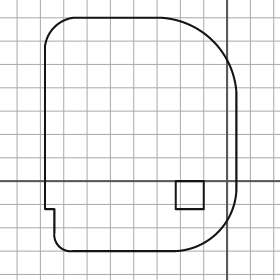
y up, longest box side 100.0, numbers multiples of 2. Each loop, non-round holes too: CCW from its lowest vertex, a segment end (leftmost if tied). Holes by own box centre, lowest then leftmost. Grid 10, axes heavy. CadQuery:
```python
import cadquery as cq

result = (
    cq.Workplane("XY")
    .moveTo(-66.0, -30.0)
    .lineTo(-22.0, -30.0)
    .threePointArc((-4.0, -22.0), (4.0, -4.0))
    .lineTo(4.0, 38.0)
    .threePointArc((-6.0, 60.0), (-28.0, 70.0))
    .lineTo(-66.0, 70.0)
    .threePointArc((-74.0, 66.0), (-78.0, 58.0))
    .lineTo(-78.0, -12.0)
    .lineTo(-74.0, -12.0)
    .lineTo(-74.0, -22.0)
    .threePointArc((-72.0, -28.0), (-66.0, -30.0))
    .close()
    .moveTo(-22.0, -12.0)
    .lineTo(-10.0, -12.0)
    .lineTo(-10.0, 0.0)
    .lineTo(-22.0, 0.0)
    .close()
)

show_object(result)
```